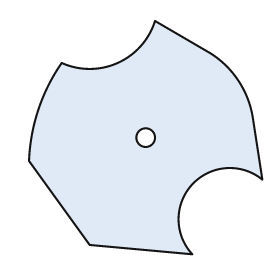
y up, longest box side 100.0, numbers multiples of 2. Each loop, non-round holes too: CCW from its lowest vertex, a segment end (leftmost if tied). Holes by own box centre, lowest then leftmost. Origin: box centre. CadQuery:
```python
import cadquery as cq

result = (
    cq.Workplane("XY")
    .moveTo(20.0, -50.0)
    .threePointArc((20.0, -20.0), (50.0, -18.0))
    .lineTo(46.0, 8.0)
    .threePointArc((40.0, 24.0), (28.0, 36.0))
    .lineTo(4.0, 50.0)
    .threePointArc((-12.0, 32.0), (-36.0, 32.0))
    .threePointArc((-46.0, 12.0), (-50.0, -10.0))
    .lineTo(-24.0, -46.0)
    .close()
    .moveTo(0.0, 0.0)
    .circle(4.0)
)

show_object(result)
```